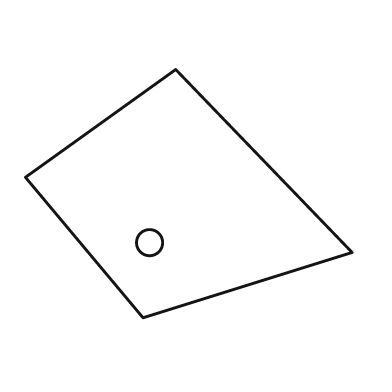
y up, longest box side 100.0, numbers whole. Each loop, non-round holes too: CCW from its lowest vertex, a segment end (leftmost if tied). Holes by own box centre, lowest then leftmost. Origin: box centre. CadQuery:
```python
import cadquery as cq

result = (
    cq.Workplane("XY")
    .moveTo(-14.0, -38.0)
    .lineTo(50.0, -18.0)
    .lineTo(-4.0, 38.0)
    .lineTo(-50.0, 5.0)
    .close()
    .moveTo(-12.0, -15.0)
    .circle(4.0)
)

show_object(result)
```